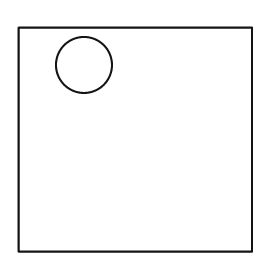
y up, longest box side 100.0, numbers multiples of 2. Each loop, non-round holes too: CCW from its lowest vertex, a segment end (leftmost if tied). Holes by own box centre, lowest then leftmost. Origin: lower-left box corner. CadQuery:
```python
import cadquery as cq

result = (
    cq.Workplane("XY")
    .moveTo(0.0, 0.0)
    .lineTo(100.0, 0.0)
    .lineTo(100.0, 96.0)
    .lineTo(0.0, 96.0)
    .close()
    .moveTo(28.0, 80.0)
    .circle(12.0)
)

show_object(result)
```